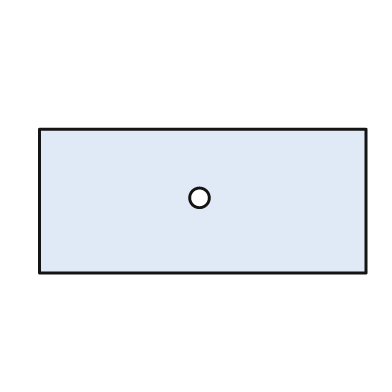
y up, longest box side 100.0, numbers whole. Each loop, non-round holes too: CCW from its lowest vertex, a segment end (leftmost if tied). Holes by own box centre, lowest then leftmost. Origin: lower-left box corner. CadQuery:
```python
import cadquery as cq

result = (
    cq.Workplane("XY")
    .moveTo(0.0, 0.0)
    .lineTo(100.0, 0.0)
    .lineTo(100.0, 44.0)
    .lineTo(0.0, 44.0)
    .close()
    .moveTo(49.0, 23.0)
    .circle(3.0)
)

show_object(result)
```